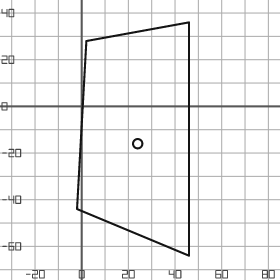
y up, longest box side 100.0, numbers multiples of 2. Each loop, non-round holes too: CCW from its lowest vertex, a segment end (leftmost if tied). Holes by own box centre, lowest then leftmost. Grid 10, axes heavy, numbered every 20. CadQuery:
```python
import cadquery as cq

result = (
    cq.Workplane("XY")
    .moveTo(46.0, -64.0)
    .lineTo(46.0, 36.0)
    .lineTo(2.0, 28.0)
    .lineTo(-2.0, -44.0)
    .close()
    .moveTo(24.0, -16.0)
    .circle(2.0)
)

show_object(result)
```